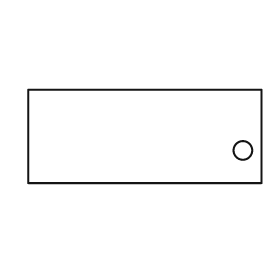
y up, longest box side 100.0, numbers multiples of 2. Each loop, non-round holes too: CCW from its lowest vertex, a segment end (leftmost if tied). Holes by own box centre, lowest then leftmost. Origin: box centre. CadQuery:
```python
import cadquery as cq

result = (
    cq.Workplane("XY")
    .moveTo(-50.0, -20.0)
    .lineTo(50.0, -20.0)
    .lineTo(50.0, 20.0)
    .lineTo(-50.0, 20.0)
    .close()
    .moveTo(42.0, -6.0)
    .circle(4.0)
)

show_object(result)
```